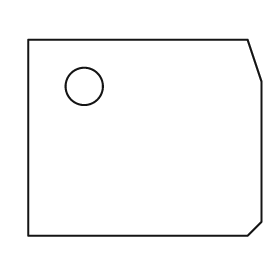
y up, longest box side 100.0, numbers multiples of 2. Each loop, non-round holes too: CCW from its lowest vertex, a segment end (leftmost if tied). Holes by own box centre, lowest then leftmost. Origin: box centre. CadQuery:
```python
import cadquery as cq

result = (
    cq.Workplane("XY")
    .moveTo(-50.0, -42.0)
    .lineTo(44.0, -42.0)
    .lineTo(50.0, -36.0)
    .lineTo(50.0, 24.0)
    .lineTo(44.0, 42.0)
    .lineTo(-50.0, 42.0)
    .close()
    .moveTo(-26.0, 22.0)
    .circle(8.0)
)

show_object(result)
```